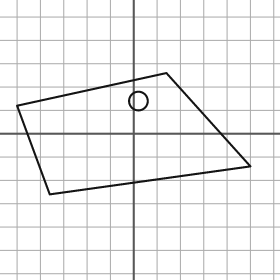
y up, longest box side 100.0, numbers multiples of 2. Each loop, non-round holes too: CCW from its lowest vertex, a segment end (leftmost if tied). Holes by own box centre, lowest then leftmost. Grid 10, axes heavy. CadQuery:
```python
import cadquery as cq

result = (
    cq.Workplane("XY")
    .moveTo(-36.0, -26.0)
    .lineTo(50.0, -14.0)
    .lineTo(14.0, 26.0)
    .lineTo(-50.0, 12.0)
    .close()
    .moveTo(2.0, 14.0)
    .circle(4.0)
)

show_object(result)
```